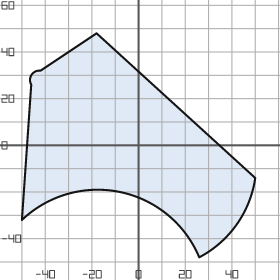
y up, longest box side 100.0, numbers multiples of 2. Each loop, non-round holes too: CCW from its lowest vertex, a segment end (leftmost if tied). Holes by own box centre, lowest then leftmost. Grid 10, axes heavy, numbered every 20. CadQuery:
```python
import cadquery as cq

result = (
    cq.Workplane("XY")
    .moveTo(26.0, -48.0)
    .threePointArc((42.0, -34.0), (50.0, -14.0))
    .lineTo(-18.0, 48.0)
    .lineTo(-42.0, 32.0)
    .threePointArc((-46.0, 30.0), (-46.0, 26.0))
    .lineTo(-50.0, -32.0)
    .threePointArc((-8.0, -20.0), (26.0, -48.0))
    .close()
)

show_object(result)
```